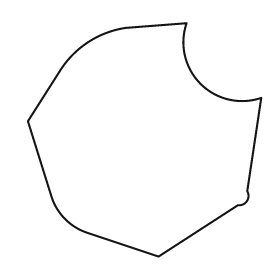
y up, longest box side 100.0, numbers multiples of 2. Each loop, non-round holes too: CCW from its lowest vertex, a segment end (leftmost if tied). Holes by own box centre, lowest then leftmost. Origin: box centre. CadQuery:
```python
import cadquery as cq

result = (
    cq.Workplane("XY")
    .moveTo(6.0, -50.0)
    .lineTo(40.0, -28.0)
    .threePointArc((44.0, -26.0), (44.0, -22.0))
    .lineTo(50.0, 18.0)
    .threePointArc((24.0, 24.0), (18.0, 50.0))
    .lineTo(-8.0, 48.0)
    .threePointArc((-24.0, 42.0), (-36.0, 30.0))
    .lineTo(-50.0, 8.0)
    .lineTo(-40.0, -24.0)
    .threePointArc((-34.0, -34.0), (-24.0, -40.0))
    .close()
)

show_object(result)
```